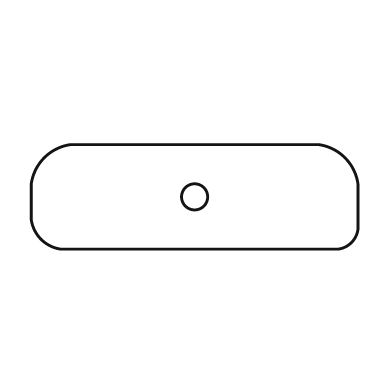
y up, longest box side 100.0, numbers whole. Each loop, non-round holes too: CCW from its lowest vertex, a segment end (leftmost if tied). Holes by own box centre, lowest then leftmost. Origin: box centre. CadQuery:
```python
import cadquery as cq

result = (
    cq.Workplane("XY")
    .moveTo(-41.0, -16.0)
    .lineTo(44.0, -16.0)
    .threePointArc((48.0, -14.0), (50.0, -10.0))
    .lineTo(50.0, 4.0)
    .threePointArc((46.0, 12.0), (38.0, 16.0))
    .lineTo(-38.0, 16.0)
    .threePointArc((-46.0, 12.0), (-50.0, 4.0))
    .lineTo(-50.0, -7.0)
    .threePointArc((-47.0, -13.0), (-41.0, -16.0))
    .close()
    .moveTo(0.0, 0.0)
    .circle(4.0)
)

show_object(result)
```